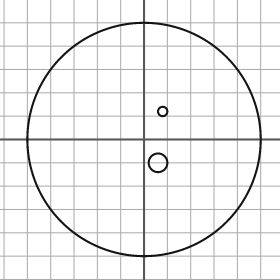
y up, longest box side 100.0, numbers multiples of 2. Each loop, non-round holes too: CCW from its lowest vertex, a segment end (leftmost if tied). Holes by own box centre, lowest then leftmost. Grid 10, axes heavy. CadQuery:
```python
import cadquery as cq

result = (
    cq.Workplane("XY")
    .moveTo(0.0, 0.0)
    .circle(50.0)
    .moveTo(6.0, -10.0)
    .circle(4.0)
    .moveTo(8.0, 12.0)
    .circle(2.0)
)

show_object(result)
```